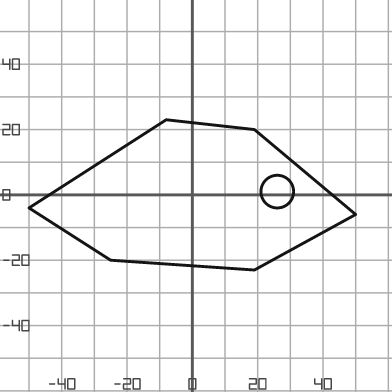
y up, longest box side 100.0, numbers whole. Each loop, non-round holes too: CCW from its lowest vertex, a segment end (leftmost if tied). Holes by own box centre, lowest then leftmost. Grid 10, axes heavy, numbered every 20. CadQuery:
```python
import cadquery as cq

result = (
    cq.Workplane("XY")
    .moveTo(19.0, -23.0)
    .lineTo(50.0, -6.0)
    .lineTo(19.0, 20.0)
    .lineTo(-8.0, 23.0)
    .lineTo(-50.0, -4.0)
    .lineTo(-25.0, -20.0)
    .close()
    .moveTo(26.0, 1.0)
    .circle(5.0)
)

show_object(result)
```